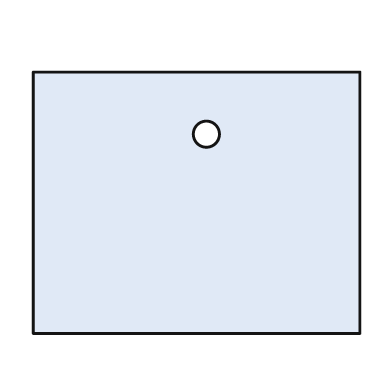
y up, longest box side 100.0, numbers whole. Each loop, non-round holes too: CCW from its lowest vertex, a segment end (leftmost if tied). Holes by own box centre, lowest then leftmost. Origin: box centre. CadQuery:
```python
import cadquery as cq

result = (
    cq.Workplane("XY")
    .moveTo(-50.0, -40.0)
    .lineTo(50.0, -40.0)
    .lineTo(50.0, 40.0)
    .lineTo(-50.0, 40.0)
    .close()
    .moveTo(3.0, 21.0)
    .circle(4.0)
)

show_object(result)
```